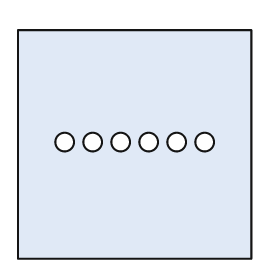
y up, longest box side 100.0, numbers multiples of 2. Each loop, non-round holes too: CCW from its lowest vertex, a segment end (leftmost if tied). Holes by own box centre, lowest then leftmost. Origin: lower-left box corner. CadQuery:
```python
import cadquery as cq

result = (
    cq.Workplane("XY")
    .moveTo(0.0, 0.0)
    .lineTo(100.0, 0.0)
    .lineTo(100.0, 98.0)
    .lineTo(0.0, 98.0)
    .close()
    .moveTo(20.0, 50.0)
    .circle(4.0)
    .moveTo(32.0, 50.0)
    .circle(4.0)
    .moveTo(44.0, 50.0)
    .circle(4.0)
    .moveTo(56.0, 50.0)
    .circle(4.0)
    .moveTo(68.0, 50.0)
    .circle(4.0)
    .moveTo(80.0, 50.0)
    .circle(4.0)
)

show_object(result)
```